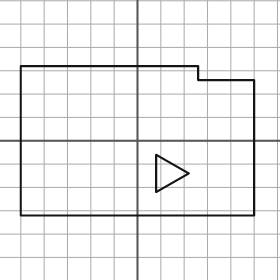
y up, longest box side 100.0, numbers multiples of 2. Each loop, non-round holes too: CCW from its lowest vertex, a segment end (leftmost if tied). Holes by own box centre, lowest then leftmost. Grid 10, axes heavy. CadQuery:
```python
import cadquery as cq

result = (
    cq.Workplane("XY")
    .moveTo(-50.0, -32.0)
    .lineTo(50.0, -32.0)
    .lineTo(50.0, 26.0)
    .lineTo(26.0, 26.0)
    .lineTo(26.0, 32.0)
    .lineTo(-50.0, 32.0)
    .close()
    .moveTo(8.0, -22.0)
    .lineTo(22.0, -14.0)
    .lineTo(8.0, -6.0)
    .close()
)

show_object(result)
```